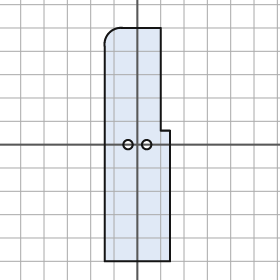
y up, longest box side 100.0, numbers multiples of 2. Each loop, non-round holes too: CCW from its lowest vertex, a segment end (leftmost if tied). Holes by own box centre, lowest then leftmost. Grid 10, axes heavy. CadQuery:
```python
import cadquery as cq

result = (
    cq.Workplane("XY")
    .moveTo(-14.0, -50.0)
    .lineTo(14.0, -50.0)
    .lineTo(14.0, 6.0)
    .lineTo(10.0, 6.0)
    .lineTo(10.0, 50.0)
    .lineTo(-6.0, 50.0)
    .threePointArc((-12.0, 48.0), (-14.0, 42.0))
    .close()
    .moveTo(-4.0, 0.0)
    .circle(2.0)
    .moveTo(4.0, 0.0)
    .circle(2.0)
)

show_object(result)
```